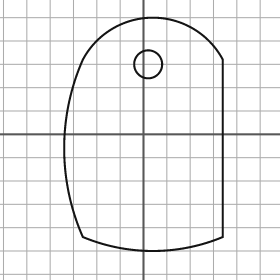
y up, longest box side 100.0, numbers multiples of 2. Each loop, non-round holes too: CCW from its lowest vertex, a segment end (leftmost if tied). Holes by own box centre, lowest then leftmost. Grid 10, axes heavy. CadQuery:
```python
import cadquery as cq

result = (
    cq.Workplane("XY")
    .moveTo(-26.0, -44.0)
    .threePointArc((4.0, -50.0), (34.0, -44.0))
    .lineTo(34.0, 32.0)
    .threePointArc((4.0, 50.0), (-26.0, 32.0))
    .threePointArc((-34.0, -6.0), (-26.0, -44.0))
    .close()
    .moveTo(2.0, 30.0)
    .circle(6.0)
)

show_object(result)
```